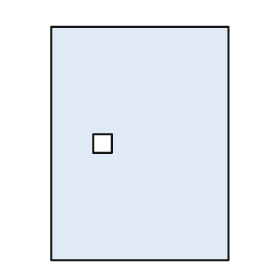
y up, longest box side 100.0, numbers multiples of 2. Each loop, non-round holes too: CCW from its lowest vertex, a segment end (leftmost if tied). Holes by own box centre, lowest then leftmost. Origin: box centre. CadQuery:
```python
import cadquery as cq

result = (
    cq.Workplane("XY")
    .moveTo(-38.0, -50.0)
    .lineTo(38.0, -50.0)
    .lineTo(38.0, 50.0)
    .lineTo(-38.0, 50.0)
    .close()
    .moveTo(-20.0, -4.0)
    .lineTo(-12.0, -4.0)
    .lineTo(-12.0, 4.0)
    .lineTo(-20.0, 4.0)
    .close()
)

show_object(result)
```